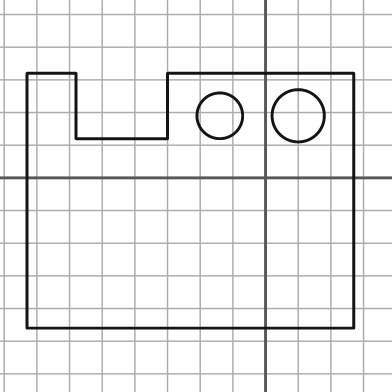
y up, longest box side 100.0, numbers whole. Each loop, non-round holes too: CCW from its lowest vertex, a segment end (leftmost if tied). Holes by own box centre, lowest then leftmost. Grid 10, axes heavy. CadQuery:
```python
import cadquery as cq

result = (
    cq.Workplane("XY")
    .moveTo(-73.0, -46.0)
    .lineTo(27.0, -46.0)
    .lineTo(27.0, 32.0)
    .lineTo(-30.0, 32.0)
    .lineTo(-30.0, 12.0)
    .lineTo(-58.0, 12.0)
    .lineTo(-58.0, 32.0)
    .lineTo(-73.0, 32.0)
    .close()
    .moveTo(-14.0, 19.0)
    .circle(7.0)
    .moveTo(10.0, 19.0)
    .circle(8.0)
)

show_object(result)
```